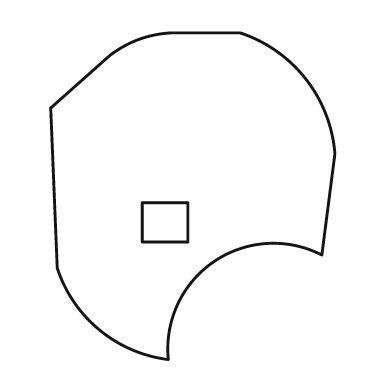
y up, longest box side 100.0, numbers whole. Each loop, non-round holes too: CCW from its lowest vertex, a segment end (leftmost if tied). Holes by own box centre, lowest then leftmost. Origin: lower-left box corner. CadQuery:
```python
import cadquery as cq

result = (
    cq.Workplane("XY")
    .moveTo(36.0, 0.0)
    .threePointArc((50.0, 30.0), (83.0, 32.0))
    .lineTo(87.0, 63.0)
    .threePointArc((78.0, 86.0), (58.0, 100.0))
    .lineTo(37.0, 100.0)
    .threePointArc((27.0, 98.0), (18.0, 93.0))
    .lineTo(0.0, 77.0)
    .lineTo(2.0, 28.0)
    .threePointArc((15.0, 9.0), (36.0, 0.0))
    .close()
    .moveTo(28.0, 36.0)
    .lineTo(42.0, 36.0)
    .lineTo(42.0, 48.0)
    .lineTo(28.0, 48.0)
    .close()
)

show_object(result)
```